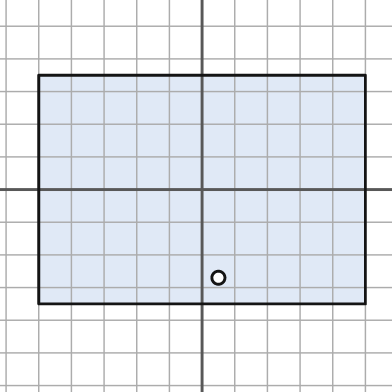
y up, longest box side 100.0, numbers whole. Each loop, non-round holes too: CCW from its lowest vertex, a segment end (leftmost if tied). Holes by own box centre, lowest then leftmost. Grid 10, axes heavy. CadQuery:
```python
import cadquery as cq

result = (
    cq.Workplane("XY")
    .moveTo(-50.0, -35.0)
    .lineTo(50.0, -35.0)
    .lineTo(50.0, 35.0)
    .lineTo(-50.0, 35.0)
    .close()
    .moveTo(5.0, -27.0)
    .circle(2.0)
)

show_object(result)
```